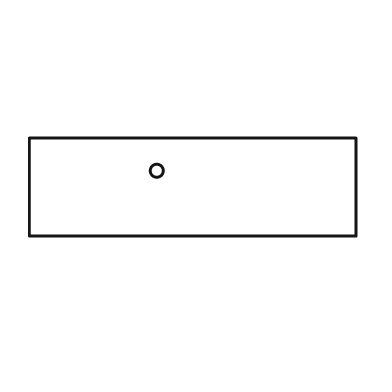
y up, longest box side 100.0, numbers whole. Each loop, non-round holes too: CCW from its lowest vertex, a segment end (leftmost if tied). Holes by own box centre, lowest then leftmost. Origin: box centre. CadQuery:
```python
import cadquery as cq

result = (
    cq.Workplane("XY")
    .moveTo(-50.0, -15.0)
    .lineTo(50.0, -15.0)
    .lineTo(50.0, 15.0)
    .lineTo(-50.0, 15.0)
    .close()
    .moveTo(-11.0, 5.0)
    .circle(2.0)
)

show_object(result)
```